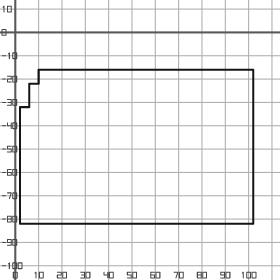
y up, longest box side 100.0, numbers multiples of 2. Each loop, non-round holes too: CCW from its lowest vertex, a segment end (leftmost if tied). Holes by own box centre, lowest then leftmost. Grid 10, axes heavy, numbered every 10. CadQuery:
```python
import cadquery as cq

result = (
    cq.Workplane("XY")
    .moveTo(2.0, -82.0)
    .lineTo(102.0, -82.0)
    .lineTo(102.0, -16.0)
    .lineTo(10.0, -16.0)
    .lineTo(10.0, -22.0)
    .lineTo(6.0, -22.0)
    .lineTo(6.0, -32.0)
    .lineTo(2.0, -32.0)
    .close()
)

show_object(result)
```